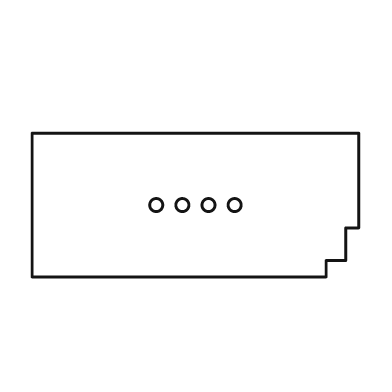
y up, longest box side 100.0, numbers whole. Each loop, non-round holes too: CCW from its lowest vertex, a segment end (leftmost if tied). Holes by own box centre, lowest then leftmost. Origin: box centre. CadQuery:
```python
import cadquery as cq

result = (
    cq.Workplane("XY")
    .moveTo(-50.0, -22.0)
    .lineTo(40.0, -22.0)
    .lineTo(40.0, -17.0)
    .lineTo(46.0, -17.0)
    .lineTo(46.0, -7.0)
    .lineTo(50.0, -7.0)
    .lineTo(50.0, 22.0)
    .lineTo(-50.0, 22.0)
    .close()
    .moveTo(-12.0, 0.0)
    .circle(2.0)
    .moveTo(-4.0, 0.0)
    .circle(2.0)
    .moveTo(4.0, 0.0)
    .circle(2.0)
    .moveTo(12.0, 0.0)
    .circle(2.0)
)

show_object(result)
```